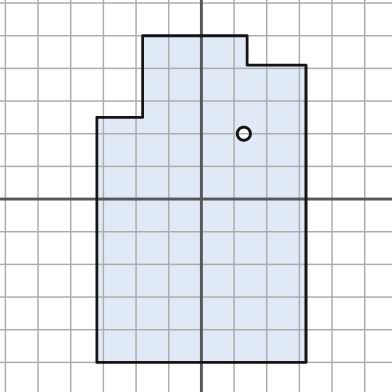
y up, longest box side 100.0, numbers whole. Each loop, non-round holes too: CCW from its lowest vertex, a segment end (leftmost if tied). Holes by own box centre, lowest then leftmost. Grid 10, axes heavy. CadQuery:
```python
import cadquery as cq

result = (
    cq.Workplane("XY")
    .moveTo(-32.0, -50.0)
    .lineTo(32.0, -50.0)
    .lineTo(32.0, 41.0)
    .lineTo(14.0, 41.0)
    .lineTo(14.0, 50.0)
    .lineTo(-18.0, 50.0)
    .lineTo(-18.0, 25.0)
    .lineTo(-32.0, 25.0)
    .close()
    .moveTo(13.0, 20.0)
    .circle(2.0)
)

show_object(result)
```